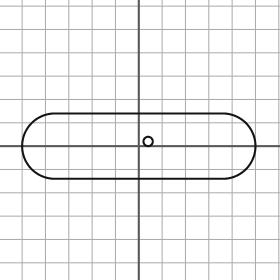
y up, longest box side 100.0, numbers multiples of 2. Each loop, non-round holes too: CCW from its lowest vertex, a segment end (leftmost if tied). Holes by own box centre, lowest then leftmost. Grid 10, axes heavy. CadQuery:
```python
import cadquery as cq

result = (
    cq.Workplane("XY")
    .moveTo(-36.0, -14.0)
    .lineTo(36.0, -14.0)
    .threePointArc((50.0, 0.0), (36.0, 14.0))
    .lineTo(-36.0, 14.0)
    .threePointArc((-50.0, 0.0), (-36.0, -14.0))
    .close()
    .moveTo(4.0, 2.0)
    .circle(2.0)
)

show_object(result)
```